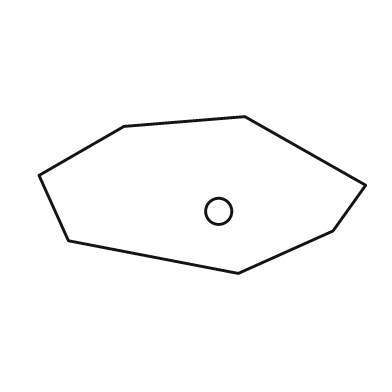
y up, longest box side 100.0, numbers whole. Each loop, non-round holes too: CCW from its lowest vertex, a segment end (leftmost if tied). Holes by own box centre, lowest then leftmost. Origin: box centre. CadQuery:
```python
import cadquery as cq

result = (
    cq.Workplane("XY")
    .moveTo(11.0, -24.0)
    .lineTo(40.0, -11.0)
    .lineTo(50.0, 3.0)
    .lineTo(13.0, 24.0)
    .lineTo(-24.0, 21.0)
    .lineTo(-50.0, 6.0)
    .lineTo(-41.0, -14.0)
    .close()
    .moveTo(5.0, -5.0)
    .circle(4.0)
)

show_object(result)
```